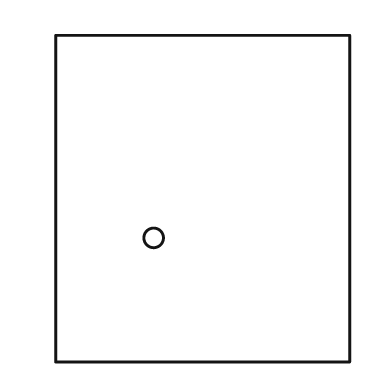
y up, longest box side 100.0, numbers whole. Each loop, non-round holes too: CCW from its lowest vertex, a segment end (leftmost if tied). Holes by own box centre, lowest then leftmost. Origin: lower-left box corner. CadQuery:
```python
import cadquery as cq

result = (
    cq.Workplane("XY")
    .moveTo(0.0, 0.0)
    .lineTo(90.0, 0.0)
    .lineTo(90.0, 100.0)
    .lineTo(0.0, 100.0)
    .close()
    .moveTo(30.0, 38.0)
    .circle(3.0)
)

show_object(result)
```